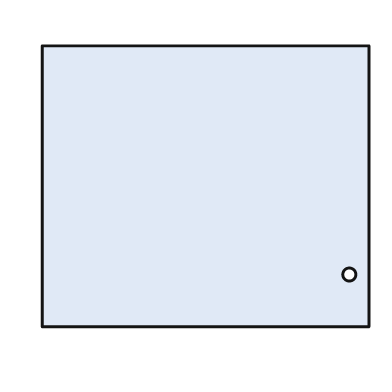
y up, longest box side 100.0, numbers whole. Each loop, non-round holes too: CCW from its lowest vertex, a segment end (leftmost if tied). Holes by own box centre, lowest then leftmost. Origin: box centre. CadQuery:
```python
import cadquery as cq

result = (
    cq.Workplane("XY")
    .moveTo(-50.0, -43.0)
    .lineTo(50.0, -43.0)
    .lineTo(50.0, 43.0)
    .lineTo(-50.0, 43.0)
    .close()
    .moveTo(44.0, -27.0)
    .circle(2.0)
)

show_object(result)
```